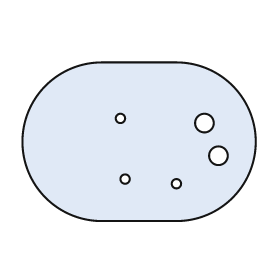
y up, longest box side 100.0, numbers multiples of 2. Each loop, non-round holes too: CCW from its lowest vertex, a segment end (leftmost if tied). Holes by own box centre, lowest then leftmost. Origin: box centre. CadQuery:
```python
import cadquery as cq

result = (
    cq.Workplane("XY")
    .moveTo(-16.0, -34.0)
    .lineTo(16.0, -34.0)
    .threePointArc((50.0, 0.0), (16.0, 34.0))
    .lineTo(-16.0, 34.0)
    .threePointArc((-50.0, 0.0), (-16.0, -34.0))
    .close()
    .moveTo(16.0, -18.0)
    .circle(2.0)
    .moveTo(-6.0, -16.0)
    .circle(2.0)
    .moveTo(34.0, -6.0)
    .circle(4.0)
    .moveTo(28.0, 8.0)
    .circle(4.0)
    .moveTo(-8.0, 10.0)
    .circle(2.0)
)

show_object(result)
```